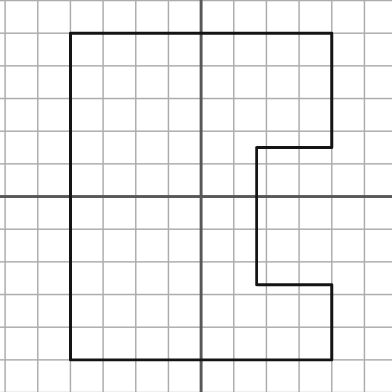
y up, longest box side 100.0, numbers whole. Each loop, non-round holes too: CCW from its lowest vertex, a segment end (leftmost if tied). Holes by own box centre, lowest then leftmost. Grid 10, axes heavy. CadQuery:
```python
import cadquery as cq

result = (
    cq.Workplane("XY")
    .moveTo(-40.0, -50.0)
    .lineTo(40.0, -50.0)
    .lineTo(40.0, -27.0)
    .lineTo(17.0, -27.0)
    .lineTo(17.0, 15.0)
    .lineTo(40.0, 15.0)
    .lineTo(40.0, 50.0)
    .lineTo(-40.0, 50.0)
    .close()
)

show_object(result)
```